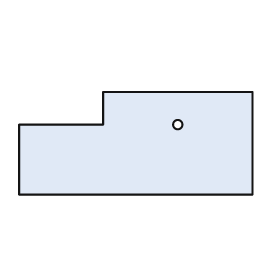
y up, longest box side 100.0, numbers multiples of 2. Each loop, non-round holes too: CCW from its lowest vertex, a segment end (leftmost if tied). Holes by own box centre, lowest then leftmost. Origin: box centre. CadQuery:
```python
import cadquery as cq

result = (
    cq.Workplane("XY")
    .moveTo(-50.0, -22.0)
    .lineTo(50.0, -22.0)
    .lineTo(50.0, 22.0)
    .lineTo(-14.0, 22.0)
    .lineTo(-14.0, 8.0)
    .lineTo(-50.0, 8.0)
    .close()
    .moveTo(18.0, 8.0)
    .circle(2.0)
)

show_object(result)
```